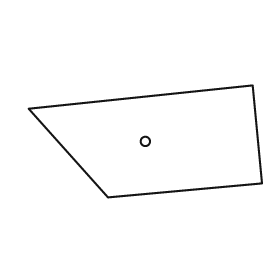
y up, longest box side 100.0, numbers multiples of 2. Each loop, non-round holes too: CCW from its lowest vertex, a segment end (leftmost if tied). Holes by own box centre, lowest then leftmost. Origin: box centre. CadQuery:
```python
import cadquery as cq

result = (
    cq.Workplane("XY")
    .moveTo(-16.0, -24.0)
    .lineTo(50.0, -18.0)
    .lineTo(46.0, 24.0)
    .lineTo(-50.0, 14.0)
    .close()
    .moveTo(0.0, 0.0)
    .circle(2.0)
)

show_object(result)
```